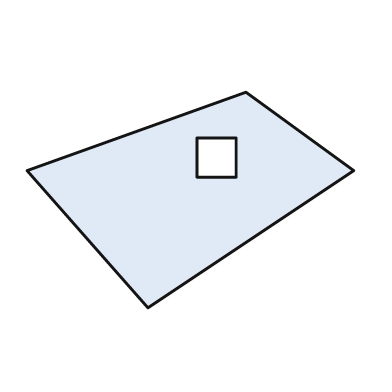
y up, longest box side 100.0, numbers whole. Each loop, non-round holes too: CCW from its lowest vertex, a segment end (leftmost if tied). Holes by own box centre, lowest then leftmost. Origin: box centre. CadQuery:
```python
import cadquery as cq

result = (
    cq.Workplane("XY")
    .moveTo(-13.0, -33.0)
    .lineTo(50.0, 9.0)
    .lineTo(17.0, 33.0)
    .lineTo(-50.0, 9.0)
    .close()
    .moveTo(2.0, 7.0)
    .lineTo(14.0, 7.0)
    .lineTo(14.0, 19.0)
    .lineTo(2.0, 19.0)
    .close()
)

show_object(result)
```